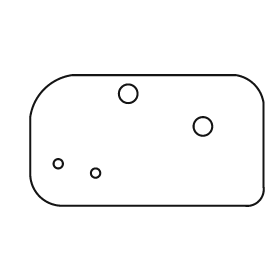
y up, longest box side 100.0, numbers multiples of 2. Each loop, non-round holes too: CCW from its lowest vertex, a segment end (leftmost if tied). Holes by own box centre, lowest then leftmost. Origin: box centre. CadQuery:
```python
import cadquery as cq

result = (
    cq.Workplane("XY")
    .moveTo(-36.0, -28.0)
    .lineTo(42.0, -28.0)
    .threePointArc((48.0, -26.0), (50.0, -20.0))
    .lineTo(50.0, 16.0)
    .threePointArc((46.0, 24.0), (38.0, 28.0))
    .lineTo(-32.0, 28.0)
    .threePointArc((-44.0, 22.0), (-50.0, 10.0))
    .lineTo(-50.0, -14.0)
    .threePointArc((-46.0, -24.0), (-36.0, -28.0))
    .close()
    .moveTo(-22.0, -14.0)
    .circle(2.0)
    .moveTo(-38.0, -10.0)
    .circle(2.0)
    .moveTo(24.0, 6.0)
    .circle(4.0)
    .moveTo(-8.0, 20.0)
    .circle(4.0)
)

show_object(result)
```